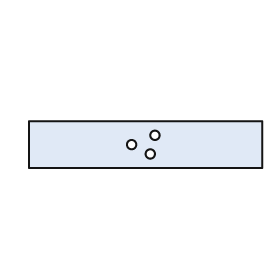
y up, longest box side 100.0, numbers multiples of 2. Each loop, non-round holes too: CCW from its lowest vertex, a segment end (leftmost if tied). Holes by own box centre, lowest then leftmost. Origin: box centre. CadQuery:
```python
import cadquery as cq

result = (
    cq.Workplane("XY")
    .moveTo(-50.0, -10.0)
    .lineTo(50.0, -10.0)
    .lineTo(50.0, 10.0)
    .lineTo(-50.0, 10.0)
    .close()
    .moveTo(2.0, -4.0)
    .circle(2.0)
    .moveTo(-6.0, 0.0)
    .circle(2.0)
    .moveTo(4.0, 4.0)
    .circle(2.0)
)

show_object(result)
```